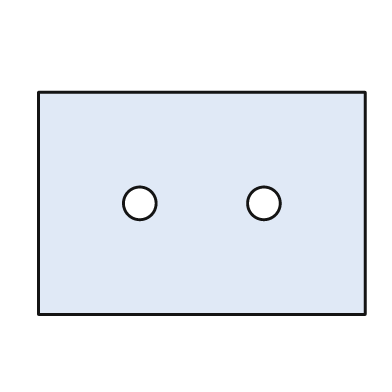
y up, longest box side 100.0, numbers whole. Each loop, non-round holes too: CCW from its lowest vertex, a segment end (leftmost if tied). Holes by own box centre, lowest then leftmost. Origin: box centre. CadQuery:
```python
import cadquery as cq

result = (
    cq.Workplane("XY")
    .moveTo(-50.0, -34.0)
    .lineTo(50.0, -34.0)
    .lineTo(50.0, 34.0)
    .lineTo(-50.0, 34.0)
    .close()
    .moveTo(-19.0, 0.0)
    .circle(5.0)
    .moveTo(19.0, 0.0)
    .circle(5.0)
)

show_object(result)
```